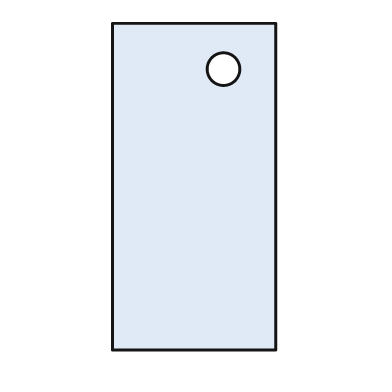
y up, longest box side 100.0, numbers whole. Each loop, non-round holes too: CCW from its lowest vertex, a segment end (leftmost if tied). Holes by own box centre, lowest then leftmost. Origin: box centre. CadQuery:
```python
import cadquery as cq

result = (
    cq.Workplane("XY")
    .moveTo(-25.0, -50.0)
    .lineTo(25.0, -50.0)
    .lineTo(25.0, 50.0)
    .lineTo(-25.0, 50.0)
    .close()
    .moveTo(9.0, 36.0)
    .circle(5.0)
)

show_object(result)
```